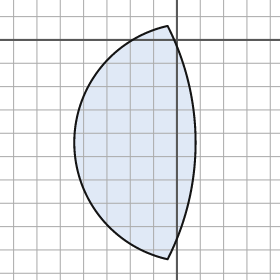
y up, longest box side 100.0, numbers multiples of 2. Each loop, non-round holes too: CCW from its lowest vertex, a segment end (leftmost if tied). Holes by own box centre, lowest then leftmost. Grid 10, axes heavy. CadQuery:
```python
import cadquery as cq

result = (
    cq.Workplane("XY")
    .moveTo(-4.0, -94.0)
    .threePointArc((8.0, -44.0), (-4.0, 6.0))
    .threePointArc((-44.0, -44.0), (-4.0, -94.0))
    .close()
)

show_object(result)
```